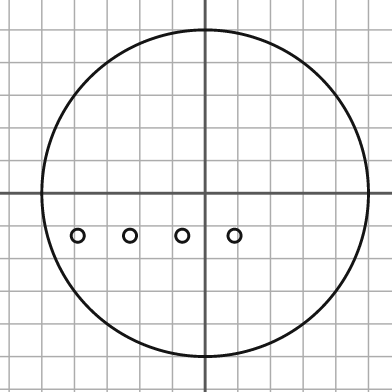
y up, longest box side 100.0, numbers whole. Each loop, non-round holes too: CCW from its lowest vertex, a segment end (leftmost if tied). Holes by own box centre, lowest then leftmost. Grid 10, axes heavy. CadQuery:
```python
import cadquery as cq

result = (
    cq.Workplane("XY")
    .moveTo(0.0, 0.0)
    .circle(50.0)
    .moveTo(-39.0, -13.0)
    .circle(2.0)
    .moveTo(-23.0, -13.0)
    .circle(2.0)
    .moveTo(-7.0, -13.0)
    .circle(2.0)
    .moveTo(9.0, -13.0)
    .circle(2.0)
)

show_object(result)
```